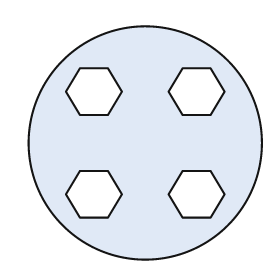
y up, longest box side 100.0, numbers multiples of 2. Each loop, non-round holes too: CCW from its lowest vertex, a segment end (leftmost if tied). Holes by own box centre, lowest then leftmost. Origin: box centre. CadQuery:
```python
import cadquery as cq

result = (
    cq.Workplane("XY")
    .moveTo(0.0, 0.0)
    .circle(50.0)
    .moveTo(-28.0, -32.0)
    .lineTo(-16.0, -32.0)
    .lineTo(-10.0, -22.0)
    .lineTo(-16.0, -12.0)
    .lineTo(-28.0, -12.0)
    .lineTo(-34.0, -22.0)
    .close()
    .moveTo(16.0, -32.0)
    .lineTo(28.0, -32.0)
    .lineTo(34.0, -22.0)
    .lineTo(28.0, -12.0)
    .lineTo(16.0, -12.0)
    .lineTo(10.0, -22.0)
    .close()
    .moveTo(-28.0, 12.0)
    .lineTo(-16.0, 12.0)
    .lineTo(-10.0, 22.0)
    .lineTo(-16.0, 32.0)
    .lineTo(-28.0, 32.0)
    .lineTo(-34.0, 22.0)
    .close()
    .moveTo(16.0, 12.0)
    .lineTo(28.0, 12.0)
    .lineTo(34.0, 22.0)
    .lineTo(28.0, 32.0)
    .lineTo(16.0, 32.0)
    .lineTo(10.0, 22.0)
    .close()
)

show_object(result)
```